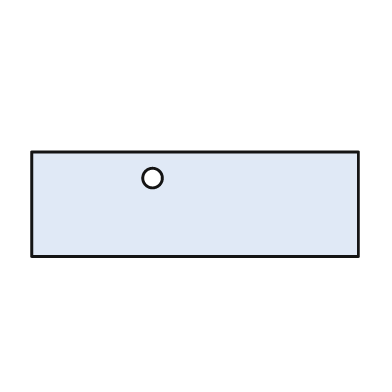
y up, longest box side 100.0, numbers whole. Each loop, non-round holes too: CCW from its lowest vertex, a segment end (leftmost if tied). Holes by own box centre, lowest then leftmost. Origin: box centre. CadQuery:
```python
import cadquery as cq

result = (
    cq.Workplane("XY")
    .moveTo(-50.0, -16.0)
    .lineTo(50.0, -16.0)
    .lineTo(50.0, 16.0)
    .lineTo(-50.0, 16.0)
    .close()
    .moveTo(-13.0, 8.0)
    .circle(3.0)
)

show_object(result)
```